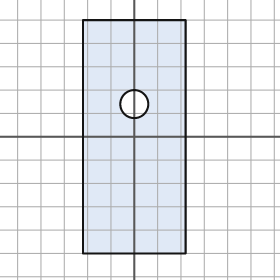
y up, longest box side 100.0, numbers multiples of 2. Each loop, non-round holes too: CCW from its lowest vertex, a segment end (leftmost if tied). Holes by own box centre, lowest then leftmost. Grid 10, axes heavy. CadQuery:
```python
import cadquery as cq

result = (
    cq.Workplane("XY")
    .moveTo(-22.0, -50.0)
    .lineTo(22.0, -50.0)
    .lineTo(22.0, 50.0)
    .lineTo(-22.0, 50.0)
    .close()
    .moveTo(0.0, 14.0)
    .circle(6.0)
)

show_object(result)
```